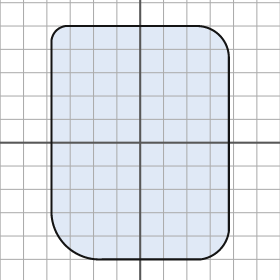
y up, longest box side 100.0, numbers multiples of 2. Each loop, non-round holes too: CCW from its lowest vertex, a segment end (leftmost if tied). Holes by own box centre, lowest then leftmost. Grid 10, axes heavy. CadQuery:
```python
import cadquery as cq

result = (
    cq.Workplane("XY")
    .moveTo(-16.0, -50.0)
    .lineTo(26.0, -50.0)
    .threePointArc((34.0, -46.0), (38.0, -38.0))
    .lineTo(38.0, 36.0)
    .threePointArc((34.0, 46.0), (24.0, 50.0))
    .lineTo(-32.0, 50.0)
    .threePointArc((-36.0, 48.0), (-38.0, 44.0))
    .lineTo(-38.0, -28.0)
    .threePointArc((-32.0, -44.0), (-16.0, -50.0))
    .close()
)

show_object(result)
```